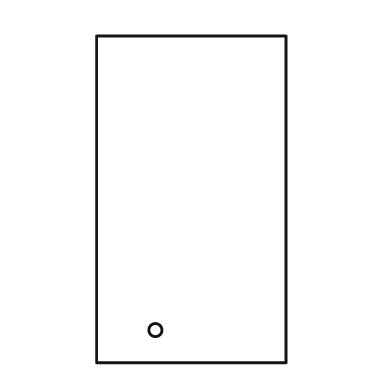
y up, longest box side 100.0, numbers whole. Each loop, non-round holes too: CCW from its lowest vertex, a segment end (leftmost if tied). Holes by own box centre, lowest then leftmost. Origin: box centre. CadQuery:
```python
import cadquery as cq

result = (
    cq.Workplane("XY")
    .moveTo(-29.0, -50.0)
    .lineTo(29.0, -50.0)
    .lineTo(29.0, 50.0)
    .lineTo(-29.0, 50.0)
    .close()
    .moveTo(-11.0, -40.0)
    .circle(2.0)
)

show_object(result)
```